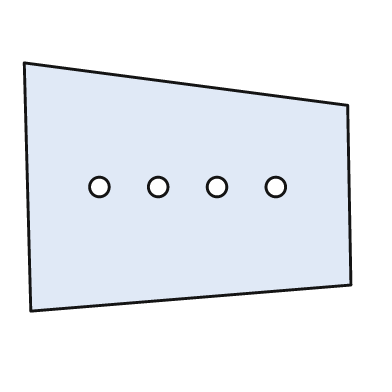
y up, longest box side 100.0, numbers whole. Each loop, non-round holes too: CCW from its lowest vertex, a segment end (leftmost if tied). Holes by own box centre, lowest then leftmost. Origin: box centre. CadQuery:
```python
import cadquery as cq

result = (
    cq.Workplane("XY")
    .moveTo(-48.0, -38.0)
    .lineTo(50.0, -30.0)
    .lineTo(49.0, 25.0)
    .lineTo(-50.0, 38.0)
    .close()
    .moveTo(-27.0, 0.0)
    .circle(3.0)
    .moveTo(-9.0, 0.0)
    .circle(3.0)
    .moveTo(9.0, 0.0)
    .circle(3.0)
    .moveTo(27.0, 0.0)
    .circle(3.0)
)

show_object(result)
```